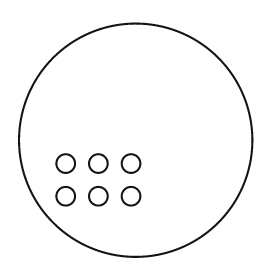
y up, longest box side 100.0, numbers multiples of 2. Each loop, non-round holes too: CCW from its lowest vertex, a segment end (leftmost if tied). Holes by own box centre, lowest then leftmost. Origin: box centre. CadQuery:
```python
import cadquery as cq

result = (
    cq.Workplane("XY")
    .moveTo(0.0, 0.0)
    .circle(50.0)
    .moveTo(-30.0, -24.0)
    .circle(4.0)
    .moveTo(-16.0, -24.0)
    .circle(4.0)
    .moveTo(-2.0, -24.0)
    .circle(4.0)
    .moveTo(-30.0, -10.0)
    .circle(4.0)
    .moveTo(-16.0, -10.0)
    .circle(4.0)
    .moveTo(-2.0, -10.0)
    .circle(4.0)
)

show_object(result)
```